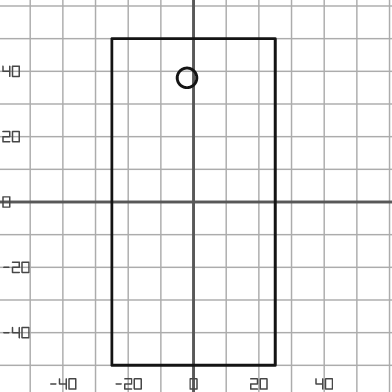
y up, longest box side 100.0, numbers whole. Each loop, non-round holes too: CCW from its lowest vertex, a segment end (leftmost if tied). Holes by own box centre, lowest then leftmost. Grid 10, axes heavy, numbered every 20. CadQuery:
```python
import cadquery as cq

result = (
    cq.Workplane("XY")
    .moveTo(-25.0, -50.0)
    .lineTo(25.0, -50.0)
    .lineTo(25.0, 50.0)
    .lineTo(-25.0, 50.0)
    .close()
    .moveTo(-2.0, 38.0)
    .circle(3.0)
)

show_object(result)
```